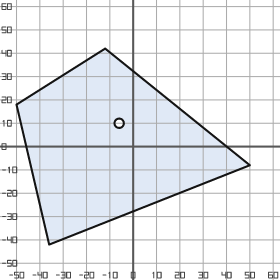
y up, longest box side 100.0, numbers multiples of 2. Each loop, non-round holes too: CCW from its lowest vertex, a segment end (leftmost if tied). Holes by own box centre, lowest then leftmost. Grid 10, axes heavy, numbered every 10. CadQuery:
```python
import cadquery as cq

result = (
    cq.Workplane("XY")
    .moveTo(-36.0, -42.0)
    .lineTo(50.0, -8.0)
    .lineTo(-12.0, 42.0)
    .lineTo(-50.0, 18.0)
    .close()
    .moveTo(-6.0, 10.0)
    .circle(2.0)
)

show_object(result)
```